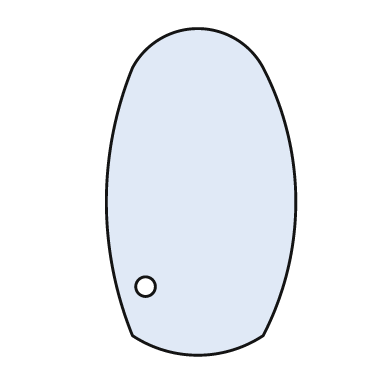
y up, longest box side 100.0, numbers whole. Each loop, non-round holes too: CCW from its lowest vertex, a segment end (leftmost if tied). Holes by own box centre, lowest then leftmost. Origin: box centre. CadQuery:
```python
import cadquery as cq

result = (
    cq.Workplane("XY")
    .moveTo(-21.0, -44.0)
    .threePointArc((-1.0, -50.0), (19.0, -44.0))
    .threePointArc((29.0, -3.0), (19.0, 38.0))
    .threePointArc((-1.0, 50.0), (-21.0, 38.0))
    .threePointArc((-29.0, -3.0), (-21.0, -44.0))
    .close()
    .moveTo(-17.0, -29.0)
    .circle(3.0)
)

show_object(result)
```